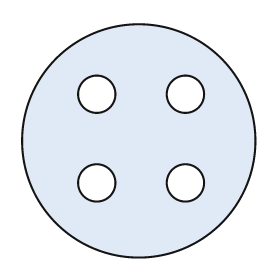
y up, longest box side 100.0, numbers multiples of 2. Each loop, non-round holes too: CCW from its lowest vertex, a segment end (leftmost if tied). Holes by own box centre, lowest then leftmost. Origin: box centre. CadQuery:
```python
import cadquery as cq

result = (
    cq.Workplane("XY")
    .moveTo(0.0, 0.0)
    .circle(50.0)
    .moveTo(-18.0, -18.0)
    .circle(8.0)
    .moveTo(20.0, -18.0)
    .circle(8.0)
    .moveTo(-18.0, 20.0)
    .circle(8.0)
    .moveTo(20.0, 20.0)
    .circle(8.0)
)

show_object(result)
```